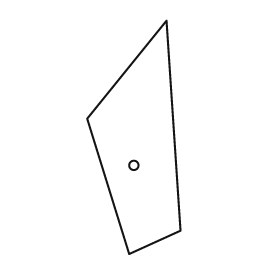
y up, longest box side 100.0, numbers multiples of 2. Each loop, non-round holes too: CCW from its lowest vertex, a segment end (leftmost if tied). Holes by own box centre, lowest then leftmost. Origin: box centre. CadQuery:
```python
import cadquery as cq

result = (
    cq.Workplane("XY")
    .moveTo(-2.0, -50.0)
    .lineTo(20.0, -40.0)
    .lineTo(14.0, 50.0)
    .lineTo(-20.0, 8.0)
    .close()
    .moveTo(0.0, -12.0)
    .circle(2.0)
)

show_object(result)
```